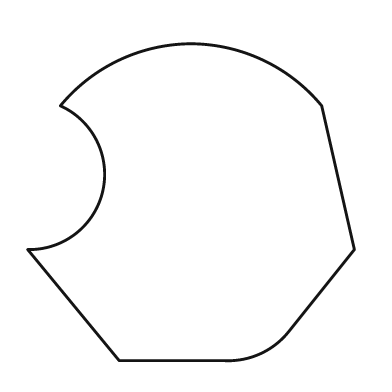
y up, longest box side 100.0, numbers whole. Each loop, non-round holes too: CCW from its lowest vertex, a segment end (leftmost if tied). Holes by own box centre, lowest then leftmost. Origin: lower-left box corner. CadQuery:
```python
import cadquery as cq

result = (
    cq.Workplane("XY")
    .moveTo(28.0, 0.0)
    .lineTo(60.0, 0.0)
    .threePointArc((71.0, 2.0), (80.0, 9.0))
    .lineTo(100.0, 34.0)
    .lineTo(90.0, 78.0)
    .threePointArc((72.0, 92.0), (50.0, 97.0))
    .threePointArc((28.0, 92.0), (10.0, 78.0))
    .threePointArc((23.0, 52.0), (0.0, 34.0))
    .close()
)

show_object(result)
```